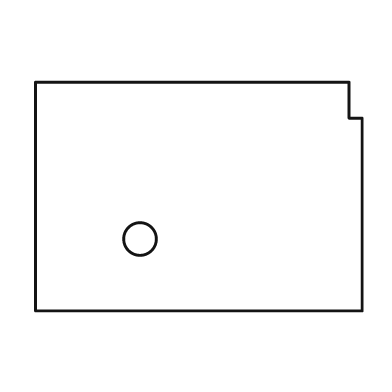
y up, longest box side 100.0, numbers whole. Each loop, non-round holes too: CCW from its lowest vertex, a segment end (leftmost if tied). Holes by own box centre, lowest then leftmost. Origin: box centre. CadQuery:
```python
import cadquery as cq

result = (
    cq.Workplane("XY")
    .moveTo(-50.0, -35.0)
    .lineTo(50.0, -35.0)
    .lineTo(50.0, 24.0)
    .lineTo(46.0, 24.0)
    .lineTo(46.0, 35.0)
    .lineTo(-50.0, 35.0)
    .close()
    .moveTo(-18.0, -13.0)
    .circle(5.0)
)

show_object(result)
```